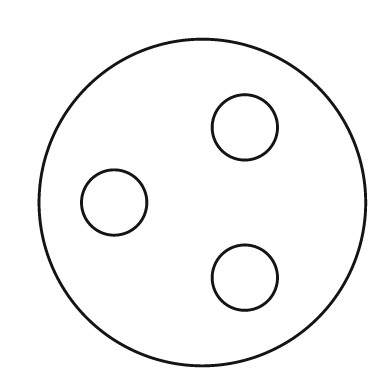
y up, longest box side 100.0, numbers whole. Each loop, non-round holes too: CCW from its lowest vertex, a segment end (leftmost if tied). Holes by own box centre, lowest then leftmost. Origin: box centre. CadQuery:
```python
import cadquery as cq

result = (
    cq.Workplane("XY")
    .moveTo(0.0, 0.0)
    .circle(50.0)
    .moveTo(13.0, -23.0)
    .circle(10.0)
    .moveTo(-27.0, 0.0)
    .circle(10.0)
    .moveTo(13.0, 23.0)
    .circle(10.0)
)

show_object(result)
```